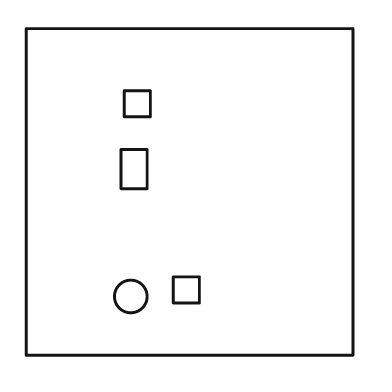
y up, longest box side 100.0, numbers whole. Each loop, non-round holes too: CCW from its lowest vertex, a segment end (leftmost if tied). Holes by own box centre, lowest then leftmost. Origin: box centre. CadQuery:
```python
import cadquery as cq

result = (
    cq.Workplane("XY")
    .moveTo(-50.0, -50.0)
    .lineTo(50.0, -50.0)
    .lineTo(50.0, 50.0)
    .lineTo(-50.0, 50.0)
    .close()
    .moveTo(-18.0, -32.0)
    .circle(5.0)
    .moveTo(-5.0, -34.0)
    .lineTo(3.0, -34.0)
    .lineTo(3.0, -26.0)
    .lineTo(-5.0, -26.0)
    .close()
    .moveTo(-21.0, 1.0)
    .lineTo(-13.0, 1.0)
    .lineTo(-13.0, 13.0)
    .lineTo(-21.0, 13.0)
    .close()
    .moveTo(-20.0, 23.0)
    .lineTo(-12.0, 23.0)
    .lineTo(-12.0, 31.0)
    .lineTo(-20.0, 31.0)
    .close()
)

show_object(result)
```